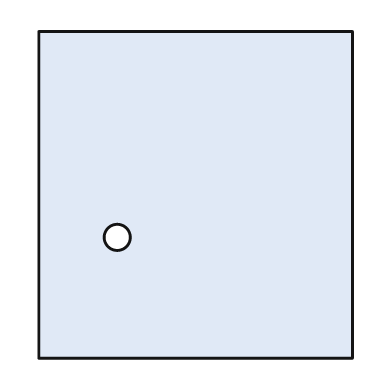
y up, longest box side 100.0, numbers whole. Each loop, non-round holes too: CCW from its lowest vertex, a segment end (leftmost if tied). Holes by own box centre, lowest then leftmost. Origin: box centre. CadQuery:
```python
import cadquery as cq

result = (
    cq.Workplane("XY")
    .moveTo(-48.0, -50.0)
    .lineTo(48.0, -50.0)
    .lineTo(48.0, 50.0)
    .lineTo(-48.0, 50.0)
    .close()
    .moveTo(-24.0, -13.0)
    .circle(4.0)
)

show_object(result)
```